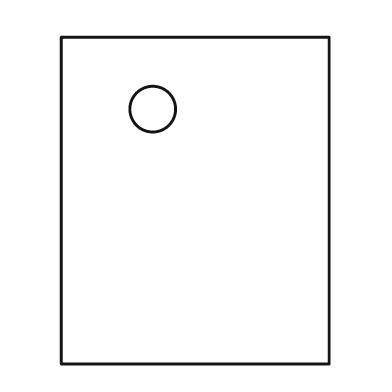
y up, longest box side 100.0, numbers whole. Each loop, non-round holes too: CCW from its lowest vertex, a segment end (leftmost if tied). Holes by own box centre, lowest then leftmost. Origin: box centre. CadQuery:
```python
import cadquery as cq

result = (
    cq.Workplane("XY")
    .moveTo(-41.0, -50.0)
    .lineTo(41.0, -50.0)
    .lineTo(41.0, 50.0)
    .lineTo(-41.0, 50.0)
    .close()
    .moveTo(-13.0, 28.0)
    .circle(7.0)
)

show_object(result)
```